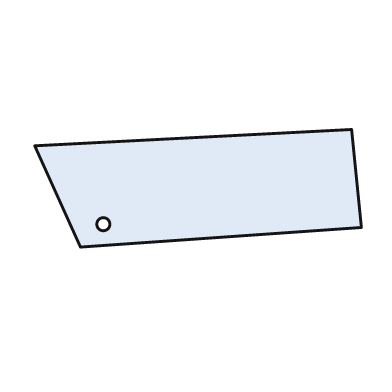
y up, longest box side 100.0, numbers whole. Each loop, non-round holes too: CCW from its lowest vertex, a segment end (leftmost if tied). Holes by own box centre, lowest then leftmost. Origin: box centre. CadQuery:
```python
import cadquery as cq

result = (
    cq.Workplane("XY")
    .moveTo(-36.0, -18.0)
    .lineTo(50.0, -12.0)
    .lineTo(47.0, 18.0)
    .lineTo(-50.0, 13.0)
    .close()
    .moveTo(-29.0, -11.0)
    .circle(2.0)
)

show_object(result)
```